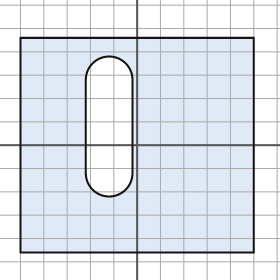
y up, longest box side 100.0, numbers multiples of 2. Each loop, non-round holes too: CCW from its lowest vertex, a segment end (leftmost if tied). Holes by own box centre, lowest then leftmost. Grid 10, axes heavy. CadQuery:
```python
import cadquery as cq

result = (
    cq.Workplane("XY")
    .moveTo(-50.0, -46.0)
    .lineTo(50.0, -46.0)
    .lineTo(50.0, 46.0)
    .lineTo(-50.0, 46.0)
    .close()
    .moveTo(-22.0, -12.0)
    .threePointArc((-12.0, -22.0), (-2.0, -12.0))
    .lineTo(-2.0, 28.0)
    .threePointArc((-12.0, 38.0), (-22.0, 28.0))
    .close()
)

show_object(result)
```